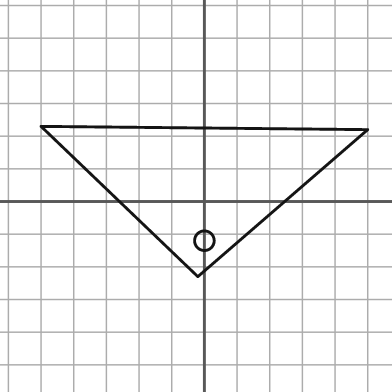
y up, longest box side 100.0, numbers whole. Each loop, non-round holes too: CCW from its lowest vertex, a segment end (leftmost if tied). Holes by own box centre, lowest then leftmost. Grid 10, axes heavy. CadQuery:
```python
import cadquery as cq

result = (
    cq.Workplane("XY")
    .moveTo(-2.0, -23.0)
    .lineTo(50.0, 22.0)
    .lineTo(-50.0, 23.0)
    .close()
    .moveTo(0.0, -12.0)
    .circle(3.0)
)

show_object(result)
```